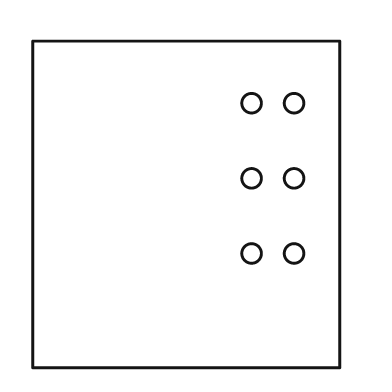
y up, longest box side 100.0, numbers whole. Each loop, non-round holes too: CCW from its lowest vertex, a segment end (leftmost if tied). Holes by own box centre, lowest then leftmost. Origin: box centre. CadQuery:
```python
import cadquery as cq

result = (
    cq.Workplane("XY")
    .moveTo(-47.0, -50.0)
    .lineTo(47.0, -50.0)
    .lineTo(47.0, 50.0)
    .lineTo(-47.0, 50.0)
    .close()
    .moveTo(20.0, -15.0)
    .circle(3.0)
    .moveTo(33.0, -15.0)
    .circle(3.0)
    .moveTo(20.0, 8.0)
    .circle(3.0)
    .moveTo(33.0, 8.0)
    .circle(3.0)
    .moveTo(20.0, 31.0)
    .circle(3.0)
    .moveTo(33.0, 31.0)
    .circle(3.0)
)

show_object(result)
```